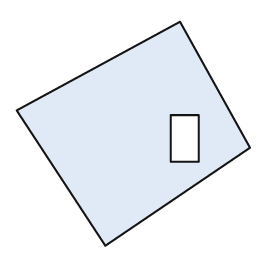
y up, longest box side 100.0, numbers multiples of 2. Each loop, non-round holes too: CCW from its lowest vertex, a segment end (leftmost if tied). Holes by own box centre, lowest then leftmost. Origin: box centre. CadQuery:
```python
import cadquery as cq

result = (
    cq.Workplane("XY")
    .moveTo(-12.0, -48.0)
    .lineTo(50.0, -6.0)
    .lineTo(20.0, 48.0)
    .lineTo(-50.0, 10.0)
    .close()
    .moveTo(16.0, -12.0)
    .lineTo(28.0, -12.0)
    .lineTo(28.0, 8.0)
    .lineTo(16.0, 8.0)
    .close()
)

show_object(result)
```